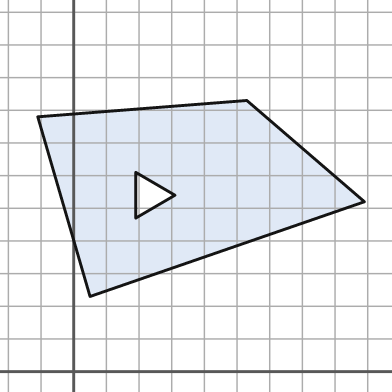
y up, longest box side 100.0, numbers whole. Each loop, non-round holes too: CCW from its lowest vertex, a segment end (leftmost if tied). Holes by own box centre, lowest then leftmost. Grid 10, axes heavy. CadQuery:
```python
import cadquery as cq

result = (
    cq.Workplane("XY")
    .moveTo(5.0, 23.0)
    .lineTo(89.0, 52.0)
    .lineTo(53.0, 83.0)
    .lineTo(-11.0, 78.0)
    .close()
    .moveTo(19.0, 47.0)
    .lineTo(31.0, 54.0)
    .lineTo(19.0, 61.0)
    .close()
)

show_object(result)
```